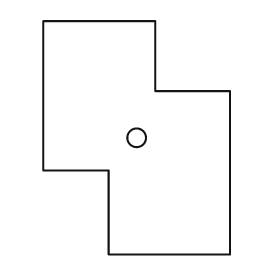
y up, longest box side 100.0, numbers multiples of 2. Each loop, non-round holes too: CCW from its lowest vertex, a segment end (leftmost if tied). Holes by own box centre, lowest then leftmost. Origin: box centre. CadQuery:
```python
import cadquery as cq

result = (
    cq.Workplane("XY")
    .moveTo(-12.0, -50.0)
    .lineTo(40.0, -50.0)
    .lineTo(40.0, 20.0)
    .lineTo(8.0, 20.0)
    .lineTo(8.0, 50.0)
    .lineTo(-40.0, 50.0)
    .lineTo(-40.0, -14.0)
    .lineTo(-12.0, -14.0)
    .close()
    .moveTo(0.0, 0.0)
    .circle(4.0)
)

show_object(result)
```